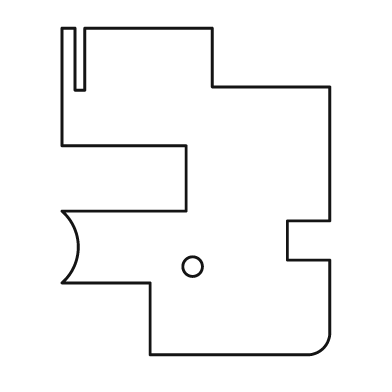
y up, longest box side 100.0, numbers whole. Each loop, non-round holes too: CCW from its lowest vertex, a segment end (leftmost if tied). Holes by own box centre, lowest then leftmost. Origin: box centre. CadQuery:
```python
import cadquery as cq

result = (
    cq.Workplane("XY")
    .moveTo(-14.0, -50.0)
    .lineTo(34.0, -50.0)
    .threePointArc((39.0, -48.0), (41.0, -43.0))
    .lineTo(41.0, -21.0)
    .lineTo(28.0, -21.0)
    .lineTo(28.0, -9.0)
    .lineTo(41.0, -9.0)
    .lineTo(41.0, 32.0)
    .lineTo(5.0, 32.0)
    .lineTo(5.0, 50.0)
    .lineTo(-34.0, 50.0)
    .lineTo(-34.0, 31.0)
    .lineTo(-37.0, 31.0)
    .lineTo(-37.0, 50.0)
    .lineTo(-41.0, 50.0)
    .lineTo(-41.0, 14.0)
    .lineTo(-3.0, 14.0)
    .lineTo(-3.0, -6.0)
    .lineTo(-41.0, -6.0)
    .threePointArc((-36.0, -17.0), (-41.0, -28.0))
    .lineTo(-14.0, -28.0)
    .close()
    .moveTo(-1.0, -23.0)
    .circle(3.0)
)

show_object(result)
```